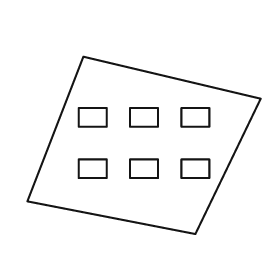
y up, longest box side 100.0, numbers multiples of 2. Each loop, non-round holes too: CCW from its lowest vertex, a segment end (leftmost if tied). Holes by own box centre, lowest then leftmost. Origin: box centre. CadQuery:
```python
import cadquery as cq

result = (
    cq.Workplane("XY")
    .moveTo(22.0, -38.0)
    .lineTo(50.0, 20.0)
    .lineTo(-26.0, 38.0)
    .lineTo(-50.0, -24.0)
    .close()
    .moveTo(-28.0, -14.0)
    .lineTo(-16.0, -14.0)
    .lineTo(-16.0, -6.0)
    .lineTo(-28.0, -6.0)
    .close()
    .moveTo(-6.0, -14.0)
    .lineTo(6.0, -14.0)
    .lineTo(6.0, -6.0)
    .lineTo(-6.0, -6.0)
    .close()
    .moveTo(16.0, -14.0)
    .lineTo(28.0, -14.0)
    .lineTo(28.0, -6.0)
    .lineTo(16.0, -6.0)
    .close()
    .moveTo(-28.0, 8.0)
    .lineTo(-16.0, 8.0)
    .lineTo(-16.0, 16.0)
    .lineTo(-28.0, 16.0)
    .close()
    .moveTo(-6.0, 8.0)
    .lineTo(6.0, 8.0)
    .lineTo(6.0, 16.0)
    .lineTo(-6.0, 16.0)
    .close()
    .moveTo(16.0, 8.0)
    .lineTo(28.0, 8.0)
    .lineTo(28.0, 16.0)
    .lineTo(16.0, 16.0)
    .close()
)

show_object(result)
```